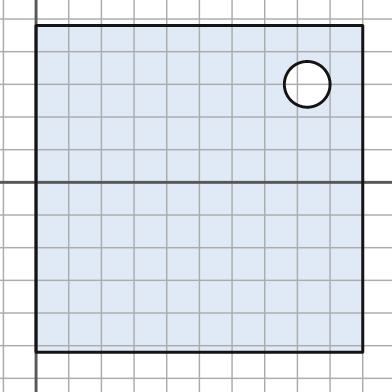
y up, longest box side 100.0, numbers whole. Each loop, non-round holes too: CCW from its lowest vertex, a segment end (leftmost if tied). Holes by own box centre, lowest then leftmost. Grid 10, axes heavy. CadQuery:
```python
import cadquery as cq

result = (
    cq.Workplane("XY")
    .moveTo(0.0, -52.0)
    .lineTo(100.0, -52.0)
    .lineTo(100.0, 48.0)
    .lineTo(0.0, 48.0)
    .close()
    .moveTo(83.0, 30.0)
    .circle(7.0)
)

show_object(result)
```